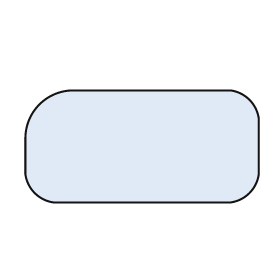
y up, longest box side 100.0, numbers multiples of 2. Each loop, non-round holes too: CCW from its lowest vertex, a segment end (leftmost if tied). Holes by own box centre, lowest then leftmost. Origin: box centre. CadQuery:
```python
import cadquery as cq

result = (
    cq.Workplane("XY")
    .moveTo(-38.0, -24.0)
    .lineTo(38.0, -24.0)
    .threePointArc((46.0, -20.0), (50.0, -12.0))
    .lineTo(50.0, 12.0)
    .threePointArc((46.0, 20.0), (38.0, 24.0))
    .lineTo(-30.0, 24.0)
    .threePointArc((-44.0, 18.0), (-50.0, 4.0))
    .lineTo(-50.0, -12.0)
    .threePointArc((-46.0, -20.0), (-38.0, -24.0))
    .close()
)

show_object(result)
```